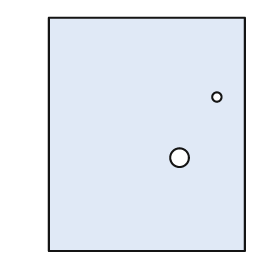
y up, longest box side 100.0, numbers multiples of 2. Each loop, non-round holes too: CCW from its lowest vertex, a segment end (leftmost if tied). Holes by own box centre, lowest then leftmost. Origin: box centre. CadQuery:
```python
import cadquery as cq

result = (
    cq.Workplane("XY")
    .moveTo(-42.0, -50.0)
    .lineTo(42.0, -50.0)
    .lineTo(42.0, 50.0)
    .lineTo(-42.0, 50.0)
    .close()
    .moveTo(14.0, -10.0)
    .circle(4.0)
    .moveTo(30.0, 16.0)
    .circle(2.0)
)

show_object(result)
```